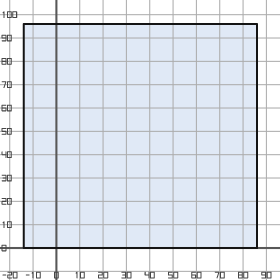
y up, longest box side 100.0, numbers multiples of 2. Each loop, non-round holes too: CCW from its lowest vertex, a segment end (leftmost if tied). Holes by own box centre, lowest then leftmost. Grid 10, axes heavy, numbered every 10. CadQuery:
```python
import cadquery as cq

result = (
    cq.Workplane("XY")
    .moveTo(-14.0, 0.0)
    .lineTo(86.0, 0.0)
    .lineTo(86.0, 96.0)
    .lineTo(-14.0, 96.0)
    .close()
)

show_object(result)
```